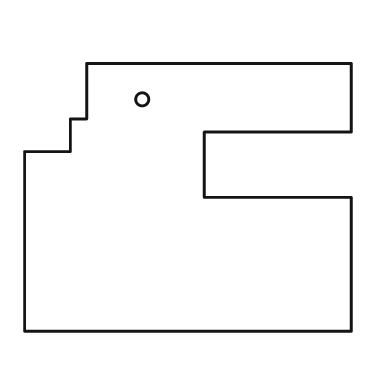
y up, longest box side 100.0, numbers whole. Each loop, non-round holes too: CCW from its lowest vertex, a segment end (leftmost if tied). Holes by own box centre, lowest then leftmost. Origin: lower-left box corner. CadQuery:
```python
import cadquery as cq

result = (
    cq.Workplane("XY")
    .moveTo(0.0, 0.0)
    .lineTo(100.0, 0.0)
    .lineTo(100.0, 41.0)
    .lineTo(55.0, 41.0)
    .lineTo(55.0, 61.0)
    .lineTo(100.0, 61.0)
    .lineTo(100.0, 82.0)
    .lineTo(19.0, 82.0)
    .lineTo(19.0, 65.0)
    .lineTo(14.0, 65.0)
    .lineTo(14.0, 55.0)
    .lineTo(0.0, 55.0)
    .close()
    .moveTo(36.0, 71.0)
    .circle(2.0)
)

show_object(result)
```